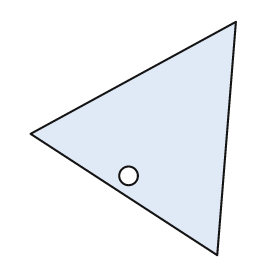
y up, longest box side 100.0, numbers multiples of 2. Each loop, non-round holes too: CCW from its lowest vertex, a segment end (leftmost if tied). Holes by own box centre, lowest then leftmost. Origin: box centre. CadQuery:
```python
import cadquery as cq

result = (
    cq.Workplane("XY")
    .moveTo(36.0, -50.0)
    .lineTo(44.0, 50.0)
    .lineTo(-44.0, 2.0)
    .close()
    .moveTo(-2.0, -16.0)
    .circle(4.0)
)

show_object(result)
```